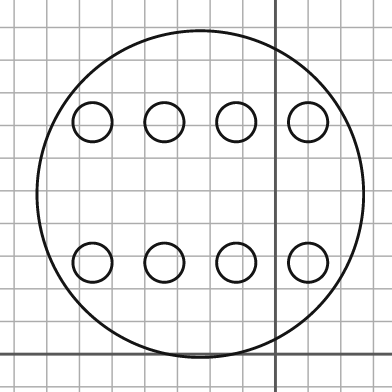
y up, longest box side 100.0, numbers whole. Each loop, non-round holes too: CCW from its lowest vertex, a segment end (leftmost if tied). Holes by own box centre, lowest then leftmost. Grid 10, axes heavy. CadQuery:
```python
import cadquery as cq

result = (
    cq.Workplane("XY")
    .moveTo(-23.0, 49.0)
    .circle(50.0)
    .moveTo(-56.0, 28.0)
    .circle(6.0)
    .moveTo(-34.0, 28.0)
    .circle(6.0)
    .moveTo(-12.0, 28.0)
    .circle(6.0)
    .moveTo(10.0, 28.0)
    .circle(6.0)
    .moveTo(-56.0, 71.0)
    .circle(6.0)
    .moveTo(-34.0, 71.0)
    .circle(6.0)
    .moveTo(-12.0, 71.0)
    .circle(6.0)
    .moveTo(10.0, 71.0)
    .circle(6.0)
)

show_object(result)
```